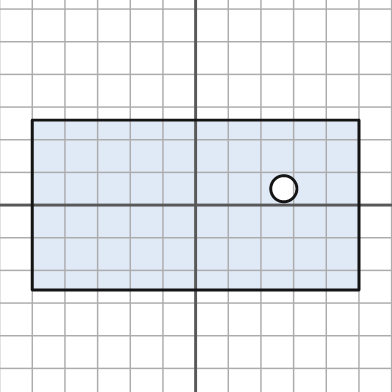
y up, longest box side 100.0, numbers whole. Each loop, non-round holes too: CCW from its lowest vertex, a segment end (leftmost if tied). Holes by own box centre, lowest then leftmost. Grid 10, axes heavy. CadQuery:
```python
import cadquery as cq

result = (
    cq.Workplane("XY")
    .moveTo(-50.0, -26.0)
    .lineTo(50.0, -26.0)
    .lineTo(50.0, 26.0)
    .lineTo(-50.0, 26.0)
    .close()
    .moveTo(27.0, 5.0)
    .circle(4.0)
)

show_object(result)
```